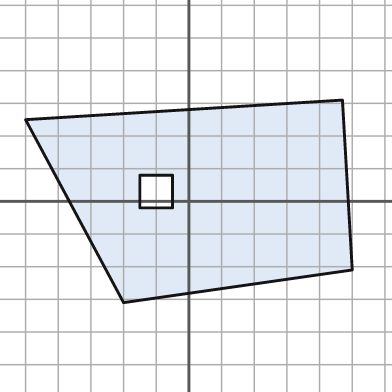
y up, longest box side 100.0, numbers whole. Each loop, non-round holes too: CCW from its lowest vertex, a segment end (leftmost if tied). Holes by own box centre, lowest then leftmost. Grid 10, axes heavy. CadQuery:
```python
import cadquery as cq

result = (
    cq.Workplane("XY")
    .moveTo(-20.0, -31.0)
    .lineTo(50.0, -21.0)
    .lineTo(47.0, 31.0)
    .lineTo(-50.0, 25.0)
    .close()
    .moveTo(-15.0, -2.0)
    .lineTo(-5.0, -2.0)
    .lineTo(-5.0, 8.0)
    .lineTo(-15.0, 8.0)
    .close()
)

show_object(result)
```